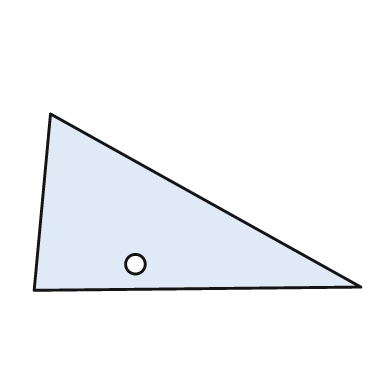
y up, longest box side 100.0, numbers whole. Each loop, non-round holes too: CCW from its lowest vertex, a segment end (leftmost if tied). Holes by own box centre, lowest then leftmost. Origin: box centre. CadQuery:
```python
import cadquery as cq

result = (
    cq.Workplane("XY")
    .moveTo(-50.0, -27.0)
    .lineTo(50.0, -26.0)
    .lineTo(-45.0, 27.0)
    .close()
    .moveTo(-19.0, -19.0)
    .circle(3.0)
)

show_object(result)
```